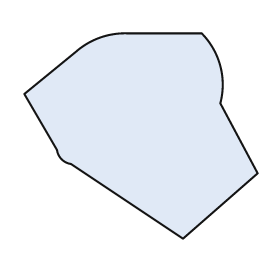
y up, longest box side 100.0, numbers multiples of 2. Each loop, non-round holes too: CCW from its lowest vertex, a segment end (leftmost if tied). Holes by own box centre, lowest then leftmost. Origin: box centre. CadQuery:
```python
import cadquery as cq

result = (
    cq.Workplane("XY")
    .moveTo(18.0, -44.0)
    .lineTo(50.0, -16.0)
    .lineTo(34.0, 14.0)
    .threePointArc((34.0, 30.0), (26.0, 44.0))
    .lineTo(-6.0, 44.0)
    .threePointArc((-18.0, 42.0), (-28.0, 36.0))
    .lineTo(-50.0, 18.0)
    .lineTo(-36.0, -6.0)
    .threePointArc((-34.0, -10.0), (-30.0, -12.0))
    .close()
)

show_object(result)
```